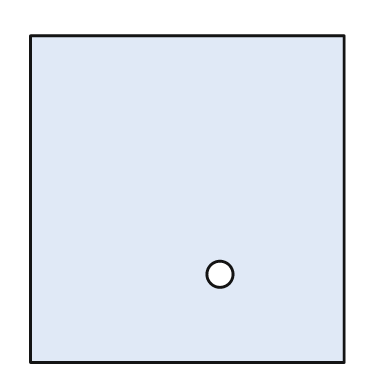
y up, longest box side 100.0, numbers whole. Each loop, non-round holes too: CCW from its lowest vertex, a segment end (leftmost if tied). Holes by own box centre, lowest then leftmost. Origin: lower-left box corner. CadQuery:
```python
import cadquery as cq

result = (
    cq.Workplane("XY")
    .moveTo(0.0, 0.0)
    .lineTo(96.0, 0.0)
    .lineTo(96.0, 100.0)
    .lineTo(0.0, 100.0)
    .close()
    .moveTo(58.0, 27.0)
    .circle(4.0)
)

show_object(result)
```